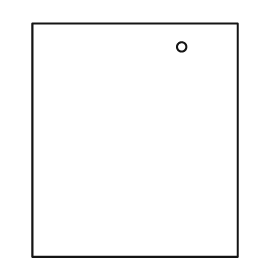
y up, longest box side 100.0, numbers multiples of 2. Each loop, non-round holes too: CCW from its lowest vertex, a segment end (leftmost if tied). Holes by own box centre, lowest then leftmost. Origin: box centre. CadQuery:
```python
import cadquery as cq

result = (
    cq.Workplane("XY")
    .moveTo(-44.0, -50.0)
    .lineTo(44.0, -50.0)
    .lineTo(44.0, 50.0)
    .lineTo(-44.0, 50.0)
    .close()
    .moveTo(20.0, 40.0)
    .circle(2.0)
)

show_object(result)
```